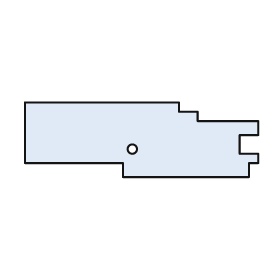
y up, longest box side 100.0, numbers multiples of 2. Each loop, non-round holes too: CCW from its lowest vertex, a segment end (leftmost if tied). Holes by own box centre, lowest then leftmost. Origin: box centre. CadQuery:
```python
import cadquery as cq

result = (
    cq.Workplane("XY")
    .moveTo(-8.0, -16.0)
    .lineTo(46.0, -16.0)
    .lineTo(46.0, -10.0)
    .lineTo(50.0, -10.0)
    .lineTo(50.0, -6.0)
    .lineTo(42.0, -6.0)
    .lineTo(42.0, 2.0)
    .lineTo(50.0, 2.0)
    .lineTo(50.0, 8.0)
    .lineTo(24.0, 8.0)
    .lineTo(24.0, 12.0)
    .lineTo(16.0, 12.0)
    .lineTo(16.0, 16.0)
    .lineTo(-50.0, 16.0)
    .lineTo(-50.0, -10.0)
    .lineTo(-8.0, -10.0)
    .close()
    .moveTo(-4.0, -4.0)
    .circle(2.0)
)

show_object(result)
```